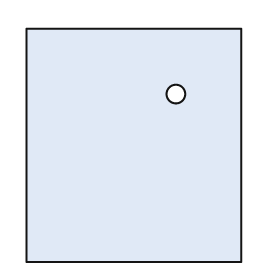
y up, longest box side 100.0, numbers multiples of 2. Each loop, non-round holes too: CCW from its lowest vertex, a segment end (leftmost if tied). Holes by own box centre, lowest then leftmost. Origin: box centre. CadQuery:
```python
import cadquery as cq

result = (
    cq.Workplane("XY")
    .moveTo(-46.0, -50.0)
    .lineTo(46.0, -50.0)
    .lineTo(46.0, 50.0)
    .lineTo(-46.0, 50.0)
    .close()
    .moveTo(18.0, 22.0)
    .circle(4.0)
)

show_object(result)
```